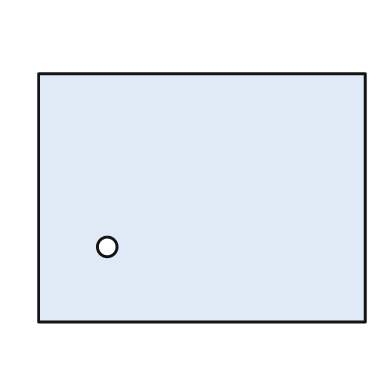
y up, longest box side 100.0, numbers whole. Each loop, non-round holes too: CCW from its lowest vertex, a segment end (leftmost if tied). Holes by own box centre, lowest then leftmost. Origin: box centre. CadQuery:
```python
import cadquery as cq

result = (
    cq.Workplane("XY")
    .moveTo(-50.0, -38.0)
    .lineTo(50.0, -38.0)
    .lineTo(50.0, 38.0)
    .lineTo(-50.0, 38.0)
    .close()
    .moveTo(-29.0, -15.0)
    .circle(3.0)
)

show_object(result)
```